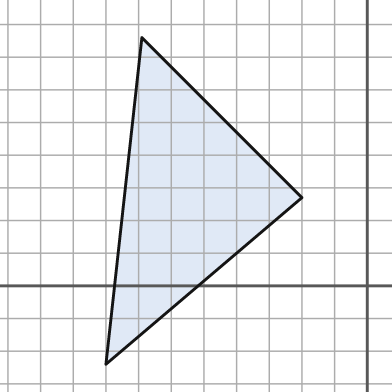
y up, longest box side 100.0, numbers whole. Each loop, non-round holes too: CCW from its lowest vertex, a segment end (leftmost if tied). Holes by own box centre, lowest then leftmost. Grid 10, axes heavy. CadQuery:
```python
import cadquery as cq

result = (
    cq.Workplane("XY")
    .moveTo(-80.0, -24.0)
    .lineTo(-20.0, 27.0)
    .lineTo(-69.0, 76.0)
    .close()
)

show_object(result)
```